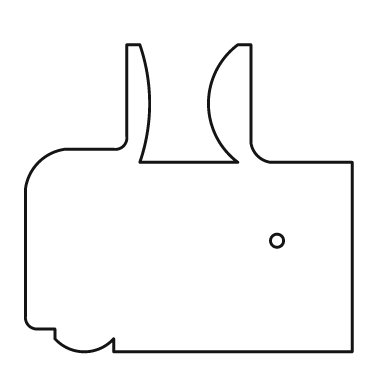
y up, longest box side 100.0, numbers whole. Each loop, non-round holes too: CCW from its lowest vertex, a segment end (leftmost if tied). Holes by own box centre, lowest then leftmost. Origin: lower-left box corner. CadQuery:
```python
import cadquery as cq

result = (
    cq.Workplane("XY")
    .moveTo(27.0, 0.0)
    .lineTo(100.0, 0.0)
    .lineTo(100.0, 58.0)
    .lineTo(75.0, 58.0)
    .threePointArc((71.0, 60.0), (69.0, 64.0))
    .lineTo(69.0, 94.0)
    .lineTo(65.0, 94.0)
    .threePointArc((56.0, 76.0), (65.0, 58.0))
    .lineTo(35.0, 58.0)
    .threePointArc((38.0, 76.0), (35.0, 94.0))
    .lineTo(31.0, 94.0)
    .lineTo(31.0, 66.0)
    .threePointArc((30.0, 63.0), (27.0, 62.0))
    .lineTo(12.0, 62.0)
    .threePointArc((4.0, 58.0), (0.0, 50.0))
    .lineTo(0.0, 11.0)
    .threePointArc((1.0, 8.0), (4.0, 7.0))
    .lineTo(9.0, 7.0)
    .lineTo(9.0, 4.0)
    .threePointArc((18.0, 0.0), (27.0, 4.0))
    .close()
    .moveTo(77.0, 34.0)
    .circle(2.0)
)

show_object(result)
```